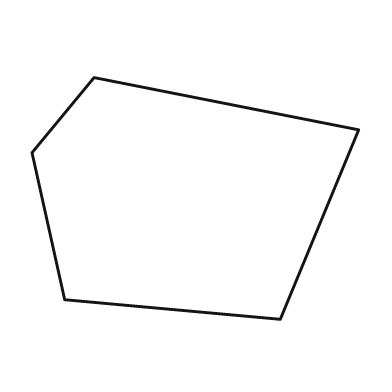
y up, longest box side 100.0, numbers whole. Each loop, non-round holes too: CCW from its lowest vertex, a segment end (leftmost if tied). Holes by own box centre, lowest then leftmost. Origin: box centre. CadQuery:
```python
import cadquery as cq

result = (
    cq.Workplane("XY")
    .moveTo(26.0, -37.0)
    .lineTo(50.0, 21.0)
    .lineTo(-31.0, 37.0)
    .lineTo(-50.0, 14.0)
    .lineTo(-40.0, -31.0)
    .close()
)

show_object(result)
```